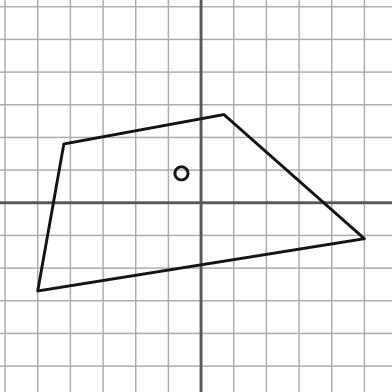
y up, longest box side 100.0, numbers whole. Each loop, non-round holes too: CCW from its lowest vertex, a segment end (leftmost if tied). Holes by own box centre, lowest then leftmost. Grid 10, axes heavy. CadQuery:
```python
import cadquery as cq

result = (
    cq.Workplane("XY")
    .moveTo(-50.0, -27.0)
    .lineTo(50.0, -11.0)
    .lineTo(7.0, 27.0)
    .lineTo(-42.0, 18.0)
    .close()
    .moveTo(-6.0, 9.0)
    .circle(2.0)
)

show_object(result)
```